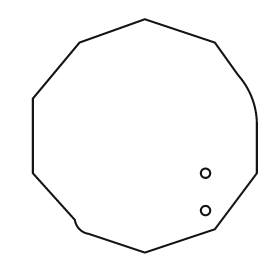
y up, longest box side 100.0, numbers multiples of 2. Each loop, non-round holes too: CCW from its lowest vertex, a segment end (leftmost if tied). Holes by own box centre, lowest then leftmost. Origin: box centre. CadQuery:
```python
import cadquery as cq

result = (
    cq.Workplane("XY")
    .moveTo(0.0, -50.0)
    .lineTo(30.0, -40.0)
    .lineTo(48.0, -16.0)
    .lineTo(48.0, 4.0)
    .threePointArc((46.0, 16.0), (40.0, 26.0))
    .lineTo(30.0, 40.0)
    .lineTo(0.0, 50.0)
    .lineTo(-28.0, 40.0)
    .lineTo(-48.0, 16.0)
    .lineTo(-48.0, -16.0)
    .lineTo(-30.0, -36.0)
    .threePointArc((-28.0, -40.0), (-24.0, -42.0))
    .close()
    .moveTo(26.0, -32.0)
    .circle(2.0)
    .moveTo(26.0, -16.0)
    .circle(2.0)
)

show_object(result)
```